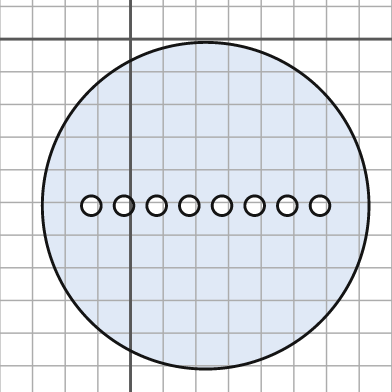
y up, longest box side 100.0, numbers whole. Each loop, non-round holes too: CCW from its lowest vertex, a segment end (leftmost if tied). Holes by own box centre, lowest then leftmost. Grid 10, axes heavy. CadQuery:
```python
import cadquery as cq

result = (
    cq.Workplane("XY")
    .moveTo(23.0, -51.0)
    .circle(50.0)
    .moveTo(-12.0, -51.0)
    .circle(3.0)
    .moveTo(-2.0, -51.0)
    .circle(3.0)
    .moveTo(8.0, -51.0)
    .circle(3.0)
    .moveTo(18.0, -51.0)
    .circle(3.0)
    .moveTo(28.0, -51.0)
    .circle(3.0)
    .moveTo(38.0, -51.0)
    .circle(3.0)
    .moveTo(48.0, -51.0)
    .circle(3.0)
    .moveTo(58.0, -51.0)
    .circle(3.0)
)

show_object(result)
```